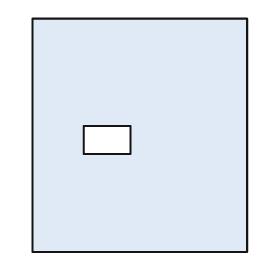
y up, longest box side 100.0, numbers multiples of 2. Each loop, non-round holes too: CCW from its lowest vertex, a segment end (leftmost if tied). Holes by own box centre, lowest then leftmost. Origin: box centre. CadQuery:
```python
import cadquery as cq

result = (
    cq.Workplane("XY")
    .moveTo(-46.0, -50.0)
    .lineTo(46.0, -50.0)
    .lineTo(46.0, 50.0)
    .lineTo(-46.0, 50.0)
    .close()
    .moveTo(-24.0, -8.0)
    .lineTo(-4.0, -8.0)
    .lineTo(-4.0, 4.0)
    .lineTo(-24.0, 4.0)
    .close()
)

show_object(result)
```